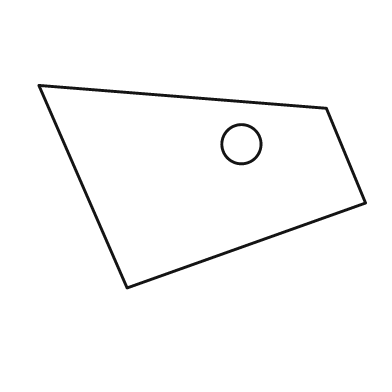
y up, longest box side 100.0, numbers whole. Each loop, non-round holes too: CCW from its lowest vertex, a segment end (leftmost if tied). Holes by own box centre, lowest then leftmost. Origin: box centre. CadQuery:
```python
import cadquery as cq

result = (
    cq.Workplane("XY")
    .moveTo(-23.0, -31.0)
    .lineTo(50.0, -5.0)
    .lineTo(38.0, 24.0)
    .lineTo(-50.0, 31.0)
    .close()
    .moveTo(12.0, 13.0)
    .circle(6.0)
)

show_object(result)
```